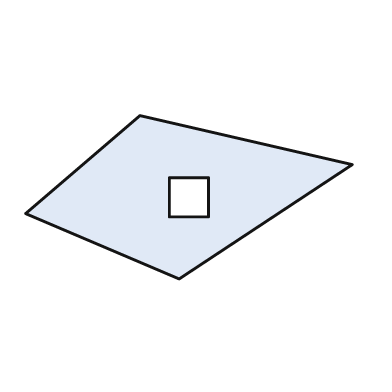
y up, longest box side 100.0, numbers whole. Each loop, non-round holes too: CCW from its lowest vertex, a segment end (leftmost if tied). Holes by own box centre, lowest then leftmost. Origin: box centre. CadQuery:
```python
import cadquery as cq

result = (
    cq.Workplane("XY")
    .moveTo(-3.0, -25.0)
    .lineTo(50.0, 10.0)
    .lineTo(-15.0, 25.0)
    .lineTo(-50.0, -5.0)
    .close()
    .moveTo(-6.0, -6.0)
    .lineTo(6.0, -6.0)
    .lineTo(6.0, 6.0)
    .lineTo(-6.0, 6.0)
    .close()
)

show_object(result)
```